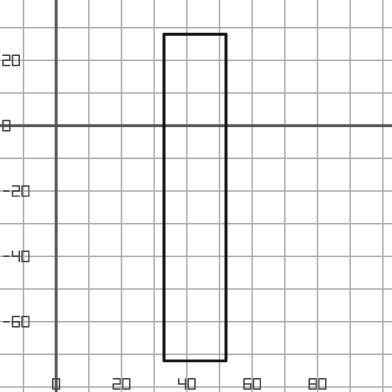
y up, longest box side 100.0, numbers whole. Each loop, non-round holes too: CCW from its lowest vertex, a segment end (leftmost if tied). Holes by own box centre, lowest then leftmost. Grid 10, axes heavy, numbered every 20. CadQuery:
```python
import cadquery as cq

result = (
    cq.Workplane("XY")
    .moveTo(33.0, -72.0)
    .lineTo(52.0, -72.0)
    .lineTo(52.0, 28.0)
    .lineTo(33.0, 28.0)
    .close()
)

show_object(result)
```